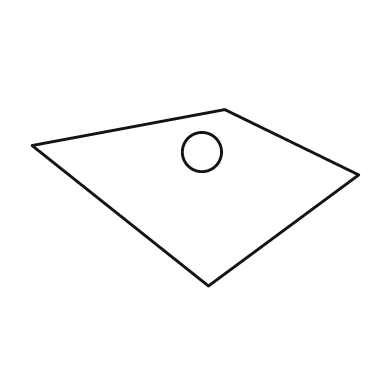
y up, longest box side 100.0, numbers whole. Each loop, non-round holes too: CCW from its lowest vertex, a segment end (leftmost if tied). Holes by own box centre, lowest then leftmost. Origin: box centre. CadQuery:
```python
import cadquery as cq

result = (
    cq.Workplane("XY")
    .moveTo(4.0, -27.0)
    .lineTo(50.0, 7.0)
    .lineTo(9.0, 27.0)
    .lineTo(-50.0, 16.0)
    .close()
    .moveTo(2.0, 14.0)
    .circle(6.0)
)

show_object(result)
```